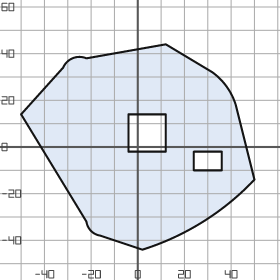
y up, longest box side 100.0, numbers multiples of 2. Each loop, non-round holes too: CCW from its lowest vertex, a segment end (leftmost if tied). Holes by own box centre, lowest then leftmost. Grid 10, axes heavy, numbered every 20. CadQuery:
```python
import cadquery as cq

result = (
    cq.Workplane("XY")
    .moveTo(2.0, -44.0)
    .threePointArc((28.0, -32.0), (50.0, -14.0))
    .lineTo(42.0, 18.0)
    .threePointArc((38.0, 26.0), (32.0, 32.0))
    .lineTo(12.0, 44.0)
    .lineTo(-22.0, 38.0)
    .threePointArc((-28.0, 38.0), (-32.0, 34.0))
    .lineTo(-50.0, 14.0)
    .lineTo(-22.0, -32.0)
    .threePointArc((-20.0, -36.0), (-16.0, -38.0))
    .close()
    .moveTo(24.0, -10.0)
    .lineTo(36.0, -10.0)
    .lineTo(36.0, -2.0)
    .lineTo(24.0, -2.0)
    .close()
    .moveTo(-4.0, -2.0)
    .lineTo(12.0, -2.0)
    .lineTo(12.0, 14.0)
    .lineTo(-4.0, 14.0)
    .close()
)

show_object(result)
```